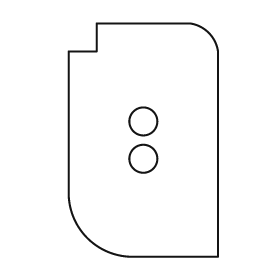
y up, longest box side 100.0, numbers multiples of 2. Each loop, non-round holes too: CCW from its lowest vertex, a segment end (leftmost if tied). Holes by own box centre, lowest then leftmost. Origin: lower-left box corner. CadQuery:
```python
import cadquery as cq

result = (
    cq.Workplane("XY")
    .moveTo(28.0, 0.0)
    .lineTo(64.0, 0.0)
    .lineTo(64.0, 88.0)
    .threePointArc((60.0, 96.0), (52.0, 100.0))
    .lineTo(12.0, 100.0)
    .lineTo(12.0, 88.0)
    .lineTo(0.0, 88.0)
    .lineTo(0.0, 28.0)
    .threePointArc((8.0, 8.0), (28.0, 0.0))
    .close()
    .moveTo(32.0, 42.0)
    .circle(6.0)
    .moveTo(32.0, 58.0)
    .circle(6.0)
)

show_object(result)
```